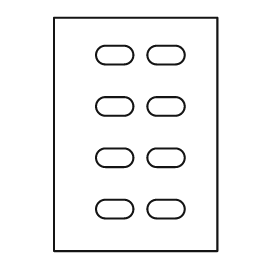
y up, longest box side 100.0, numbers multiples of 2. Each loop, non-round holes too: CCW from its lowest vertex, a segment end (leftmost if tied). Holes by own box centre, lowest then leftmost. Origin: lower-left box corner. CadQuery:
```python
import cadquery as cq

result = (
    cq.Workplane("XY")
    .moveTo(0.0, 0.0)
    .lineTo(70.0, 0.0)
    .lineTo(70.0, 100.0)
    .lineTo(0.0, 100.0)
    .close()
    .moveTo(22.0, 14.0)
    .lineTo(30.0, 14.0)
    .threePointArc((34.0, 18.0), (30.0, 22.0))
    .lineTo(22.0, 22.0)
    .threePointArc((18.0, 18.0), (22.0, 14.0))
    .close()
    .moveTo(44.0, 14.0)
    .lineTo(52.0, 14.0)
    .threePointArc((56.0, 18.0), (52.0, 22.0))
    .lineTo(44.0, 22.0)
    .threePointArc((40.0, 18.0), (44.0, 14.0))
    .close()
    .moveTo(22.0, 36.0)
    .lineTo(30.0, 36.0)
    .threePointArc((34.0, 40.0), (30.0, 44.0))
    .lineTo(22.0, 44.0)
    .threePointArc((18.0, 40.0), (22.0, 36.0))
    .close()
    .moveTo(44.0, 36.0)
    .lineTo(52.0, 36.0)
    .threePointArc((56.0, 40.0), (52.0, 44.0))
    .lineTo(44.0, 44.0)
    .threePointArc((40.0, 40.0), (44.0, 36.0))
    .close()
    .moveTo(22.0, 58.0)
    .lineTo(30.0, 58.0)
    .threePointArc((34.0, 62.0), (30.0, 66.0))
    .lineTo(22.0, 66.0)
    .threePointArc((18.0, 62.0), (22.0, 58.0))
    .close()
    .moveTo(44.0, 58.0)
    .lineTo(52.0, 58.0)
    .threePointArc((56.0, 62.0), (52.0, 66.0))
    .lineTo(44.0, 66.0)
    .threePointArc((40.0, 62.0), (44.0, 58.0))
    .close()
    .moveTo(22.0, 80.0)
    .lineTo(30.0, 80.0)
    .threePointArc((34.0, 84.0), (30.0, 88.0))
    .lineTo(22.0, 88.0)
    .threePointArc((18.0, 84.0), (22.0, 80.0))
    .close()
    .moveTo(44.0, 80.0)
    .lineTo(52.0, 80.0)
    .threePointArc((56.0, 84.0), (52.0, 88.0))
    .lineTo(44.0, 88.0)
    .threePointArc((40.0, 84.0), (44.0, 80.0))
    .close()
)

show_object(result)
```